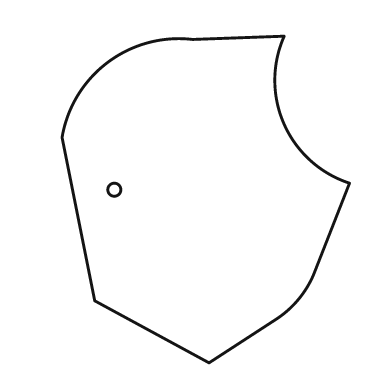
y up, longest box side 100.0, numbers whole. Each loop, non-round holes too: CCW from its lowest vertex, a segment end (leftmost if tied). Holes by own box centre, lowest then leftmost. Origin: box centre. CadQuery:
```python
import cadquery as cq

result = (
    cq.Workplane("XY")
    .moveTo(1.0, -50.0)
    .lineTo(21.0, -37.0)
    .threePointArc((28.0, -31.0), (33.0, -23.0))
    .lineTo(44.0, 5.0)
    .threePointArc((24.0, 23.0), (24.0, 50.0))
    .lineTo(-4.0, 49.0)
    .threePointArc((-30.0, 42.0), (-44.0, 19.0))
    .lineTo(-34.0, -31.0)
    .close()
    .moveTo(-28.0, 3.0)
    .circle(2.0)
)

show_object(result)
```